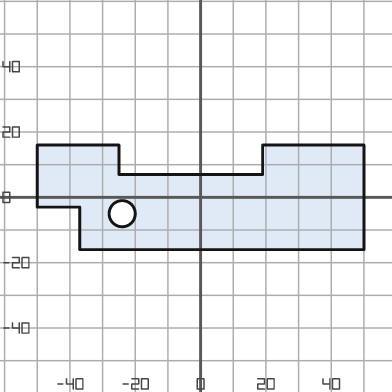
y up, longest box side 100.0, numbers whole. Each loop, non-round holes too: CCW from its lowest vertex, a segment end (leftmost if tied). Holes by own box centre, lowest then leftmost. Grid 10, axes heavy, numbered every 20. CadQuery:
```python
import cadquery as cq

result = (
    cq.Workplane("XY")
    .moveTo(-37.0, -16.0)
    .lineTo(50.0, -16.0)
    .lineTo(50.0, 16.0)
    .lineTo(19.0, 16.0)
    .lineTo(19.0, 7.0)
    .lineTo(-25.0, 7.0)
    .lineTo(-25.0, 16.0)
    .lineTo(-50.0, 16.0)
    .lineTo(-50.0, -3.0)
    .lineTo(-37.0, -3.0)
    .close()
    .moveTo(-24.0, -5.0)
    .circle(4.0)
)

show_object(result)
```